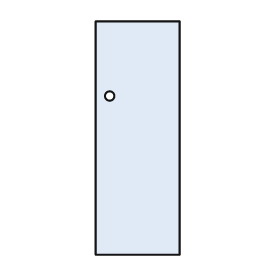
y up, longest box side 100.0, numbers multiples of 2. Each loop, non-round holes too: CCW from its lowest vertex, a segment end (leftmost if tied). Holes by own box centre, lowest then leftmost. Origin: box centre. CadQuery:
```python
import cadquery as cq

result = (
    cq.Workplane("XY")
    .moveTo(-18.0, -50.0)
    .lineTo(18.0, -50.0)
    .lineTo(18.0, 50.0)
    .lineTo(-18.0, 50.0)
    .close()
    .moveTo(-12.0, 18.0)
    .circle(2.0)
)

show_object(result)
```